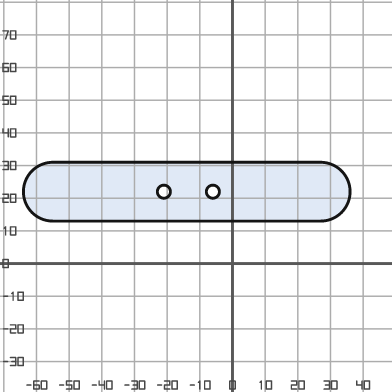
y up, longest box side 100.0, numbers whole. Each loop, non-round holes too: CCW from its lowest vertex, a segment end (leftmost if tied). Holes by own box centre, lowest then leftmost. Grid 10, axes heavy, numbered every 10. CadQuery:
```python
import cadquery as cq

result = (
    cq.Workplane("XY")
    .moveTo(-55.0, 13.0)
    .lineTo(27.0, 13.0)
    .threePointArc((36.0, 22.0), (27.0, 31.0))
    .lineTo(-55.0, 31.0)
    .threePointArc((-64.0, 22.0), (-55.0, 13.0))
    .close()
    .moveTo(-21.0, 22.0)
    .circle(2.0)
    .moveTo(-6.0, 22.0)
    .circle(2.0)
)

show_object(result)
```